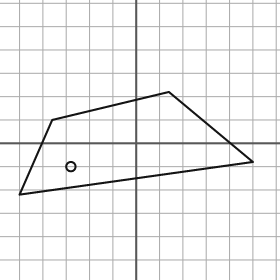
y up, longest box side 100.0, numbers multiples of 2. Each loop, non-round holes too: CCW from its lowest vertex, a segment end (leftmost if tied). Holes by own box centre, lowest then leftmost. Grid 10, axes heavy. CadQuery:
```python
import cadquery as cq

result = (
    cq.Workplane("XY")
    .moveTo(-50.0, -22.0)
    .lineTo(50.0, -8.0)
    .lineTo(14.0, 22.0)
    .lineTo(-36.0, 10.0)
    .close()
    .moveTo(-28.0, -10.0)
    .circle(2.0)
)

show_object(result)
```